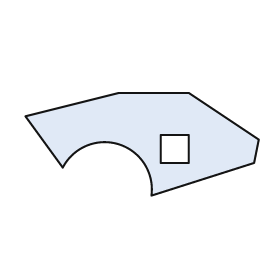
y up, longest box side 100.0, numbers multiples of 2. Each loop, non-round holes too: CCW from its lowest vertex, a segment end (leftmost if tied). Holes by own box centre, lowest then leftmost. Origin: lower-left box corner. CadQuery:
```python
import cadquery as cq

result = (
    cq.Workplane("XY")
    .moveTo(54.0, 0.0)
    .lineTo(98.0, 14.0)
    .lineTo(100.0, 24.0)
    .lineTo(70.0, 44.0)
    .lineTo(40.0, 44.0)
    .lineTo(0.0, 34.0)
    .lineTo(16.0, 12.0)
    .threePointArc((40.0, 22.0), (54.0, 0.0))
    .close()
    .moveTo(58.0, 14.0)
    .lineTo(70.0, 14.0)
    .lineTo(70.0, 26.0)
    .lineTo(58.0, 26.0)
    .close()
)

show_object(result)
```